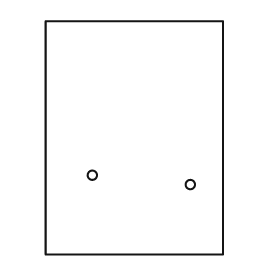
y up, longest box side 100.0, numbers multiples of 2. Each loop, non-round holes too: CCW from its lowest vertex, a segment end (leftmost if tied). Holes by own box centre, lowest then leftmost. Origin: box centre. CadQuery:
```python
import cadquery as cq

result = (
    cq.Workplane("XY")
    .moveTo(-38.0, -50.0)
    .lineTo(38.0, -50.0)
    .lineTo(38.0, 50.0)
    .lineTo(-38.0, 50.0)
    .close()
    .moveTo(24.0, -20.0)
    .circle(2.0)
    .moveTo(-18.0, -16.0)
    .circle(2.0)
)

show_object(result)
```